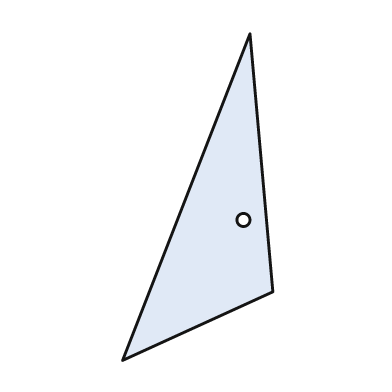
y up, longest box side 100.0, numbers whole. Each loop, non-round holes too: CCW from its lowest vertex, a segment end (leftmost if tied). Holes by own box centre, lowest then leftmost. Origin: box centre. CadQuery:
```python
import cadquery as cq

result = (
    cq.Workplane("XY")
    .moveTo(-23.0, -50.0)
    .lineTo(23.0, -29.0)
    .lineTo(16.0, 50.0)
    .close()
    .moveTo(14.0, -7.0)
    .circle(2.0)
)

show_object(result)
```